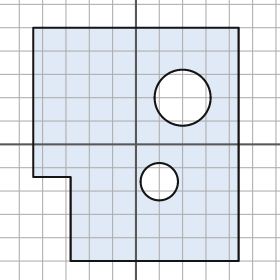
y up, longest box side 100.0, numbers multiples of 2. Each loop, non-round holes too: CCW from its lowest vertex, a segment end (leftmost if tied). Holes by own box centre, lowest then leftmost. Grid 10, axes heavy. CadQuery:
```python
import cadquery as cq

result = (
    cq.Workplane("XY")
    .moveTo(-28.0, -50.0)
    .lineTo(44.0, -50.0)
    .lineTo(44.0, 50.0)
    .lineTo(-44.0, 50.0)
    .lineTo(-44.0, -14.0)
    .lineTo(-28.0, -14.0)
    .close()
    .moveTo(10.0, -16.0)
    .circle(8.0)
    .moveTo(20.0, 20.0)
    .circle(12.0)
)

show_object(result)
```